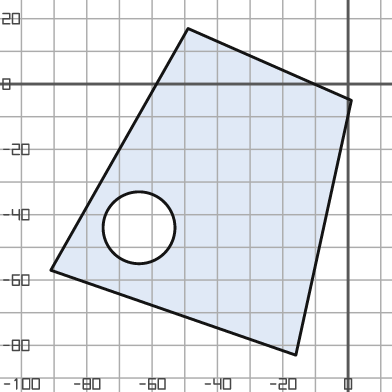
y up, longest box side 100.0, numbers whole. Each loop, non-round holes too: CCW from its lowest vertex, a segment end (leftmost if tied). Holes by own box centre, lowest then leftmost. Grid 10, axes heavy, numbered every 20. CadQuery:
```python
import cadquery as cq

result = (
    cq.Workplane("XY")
    .moveTo(-16.0, -83.0)
    .lineTo(1.0, -5.0)
    .lineTo(-49.0, 17.0)
    .lineTo(-91.0, -57.0)
    .close()
    .moveTo(-64.0, -44.0)
    .circle(11.0)
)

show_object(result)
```